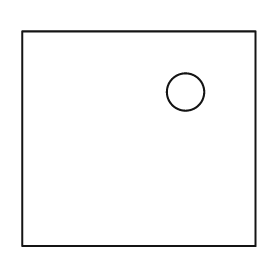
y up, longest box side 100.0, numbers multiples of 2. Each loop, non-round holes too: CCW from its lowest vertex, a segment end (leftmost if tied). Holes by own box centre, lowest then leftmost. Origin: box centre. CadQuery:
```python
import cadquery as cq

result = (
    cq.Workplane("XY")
    .moveTo(-50.0, -46.0)
    .lineTo(50.0, -46.0)
    .lineTo(50.0, 46.0)
    .lineTo(-50.0, 46.0)
    .close()
    .moveTo(20.0, 20.0)
    .circle(8.0)
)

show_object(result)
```